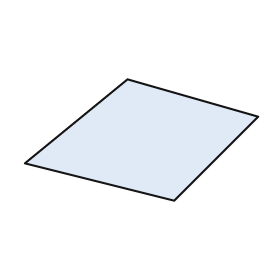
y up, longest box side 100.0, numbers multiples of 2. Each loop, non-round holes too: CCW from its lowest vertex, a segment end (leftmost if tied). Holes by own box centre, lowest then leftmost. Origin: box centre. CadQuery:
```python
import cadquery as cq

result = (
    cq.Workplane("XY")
    .moveTo(14.0, -26.0)
    .lineTo(50.0, 10.0)
    .lineTo(-6.0, 26.0)
    .lineTo(-50.0, -10.0)
    .close()
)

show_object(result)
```